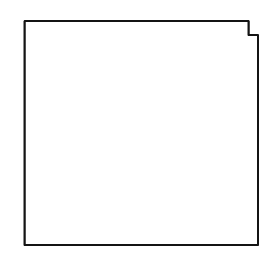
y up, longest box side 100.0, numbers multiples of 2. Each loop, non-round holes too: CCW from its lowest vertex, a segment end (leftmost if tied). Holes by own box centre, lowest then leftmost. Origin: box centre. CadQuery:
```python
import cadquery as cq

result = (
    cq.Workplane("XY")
    .moveTo(-50.0, -48.0)
    .lineTo(50.0, -48.0)
    .lineTo(50.0, 42.0)
    .lineTo(46.0, 42.0)
    .lineTo(46.0, 48.0)
    .lineTo(-50.0, 48.0)
    .close()
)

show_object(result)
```